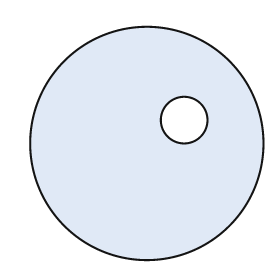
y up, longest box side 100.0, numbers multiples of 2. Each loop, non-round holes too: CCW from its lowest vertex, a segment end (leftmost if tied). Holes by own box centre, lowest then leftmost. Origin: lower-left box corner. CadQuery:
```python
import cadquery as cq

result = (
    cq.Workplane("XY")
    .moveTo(50.0, 50.0)
    .circle(50.0)
    .moveTo(66.0, 60.0)
    .circle(10.0)
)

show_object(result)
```